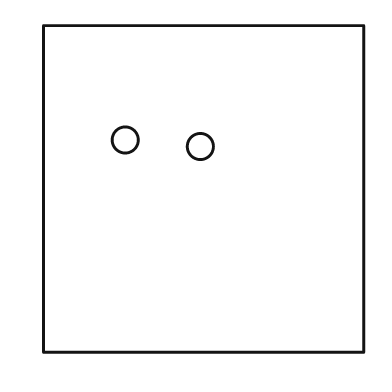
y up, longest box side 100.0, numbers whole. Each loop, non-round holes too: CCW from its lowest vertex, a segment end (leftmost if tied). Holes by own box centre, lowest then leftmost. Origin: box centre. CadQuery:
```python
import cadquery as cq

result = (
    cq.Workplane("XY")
    .moveTo(-49.0, -50.0)
    .lineTo(49.0, -50.0)
    .lineTo(49.0, 50.0)
    .lineTo(-49.0, 50.0)
    .close()
    .moveTo(-1.0, 13.0)
    .circle(4.0)
    .moveTo(-24.0, 15.0)
    .circle(4.0)
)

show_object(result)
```